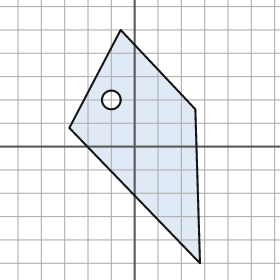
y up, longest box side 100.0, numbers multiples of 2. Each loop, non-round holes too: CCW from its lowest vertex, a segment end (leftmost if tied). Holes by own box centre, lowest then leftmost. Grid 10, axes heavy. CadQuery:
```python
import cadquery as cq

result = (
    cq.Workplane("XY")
    .moveTo(28.0, -50.0)
    .lineTo(26.0, 16.0)
    .lineTo(-6.0, 50.0)
    .lineTo(-28.0, 8.0)
    .close()
    .moveTo(-10.0, 20.0)
    .circle(4.0)
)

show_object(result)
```